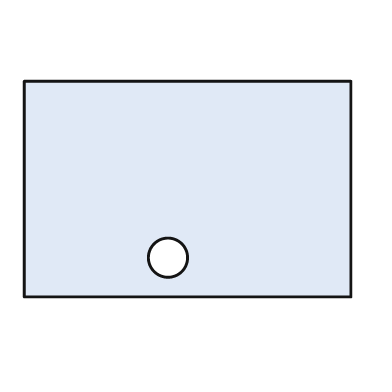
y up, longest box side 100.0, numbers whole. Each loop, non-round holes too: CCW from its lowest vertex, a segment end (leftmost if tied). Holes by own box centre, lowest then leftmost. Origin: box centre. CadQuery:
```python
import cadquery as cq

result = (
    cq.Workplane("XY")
    .moveTo(-50.0, -33.0)
    .lineTo(50.0, -33.0)
    .lineTo(50.0, 33.0)
    .lineTo(-50.0, 33.0)
    .close()
    .moveTo(-6.0, -21.0)
    .circle(6.0)
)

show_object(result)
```